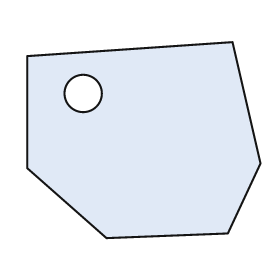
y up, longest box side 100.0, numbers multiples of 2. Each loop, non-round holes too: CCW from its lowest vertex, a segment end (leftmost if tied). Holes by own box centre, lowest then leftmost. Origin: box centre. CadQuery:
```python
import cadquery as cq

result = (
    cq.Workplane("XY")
    .moveTo(-16.0, -42.0)
    .lineTo(36.0, -40.0)
    .lineTo(50.0, -10.0)
    .lineTo(38.0, 42.0)
    .lineTo(-50.0, 36.0)
    .lineTo(-50.0, -12.0)
    .close()
    .moveTo(-26.0, 20.0)
    .circle(8.0)
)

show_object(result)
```